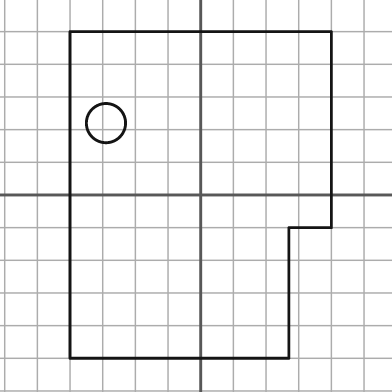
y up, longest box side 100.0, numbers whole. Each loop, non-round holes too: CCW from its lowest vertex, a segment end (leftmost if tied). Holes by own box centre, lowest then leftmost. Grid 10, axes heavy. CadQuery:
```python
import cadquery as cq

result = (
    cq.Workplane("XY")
    .moveTo(-40.0, -50.0)
    .lineTo(27.0, -50.0)
    .lineTo(27.0, -10.0)
    .lineTo(40.0, -10.0)
    .lineTo(40.0, 50.0)
    .lineTo(-40.0, 50.0)
    .close()
    .moveTo(-29.0, 22.0)
    .circle(6.0)
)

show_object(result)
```